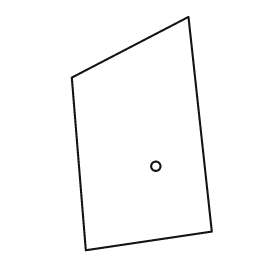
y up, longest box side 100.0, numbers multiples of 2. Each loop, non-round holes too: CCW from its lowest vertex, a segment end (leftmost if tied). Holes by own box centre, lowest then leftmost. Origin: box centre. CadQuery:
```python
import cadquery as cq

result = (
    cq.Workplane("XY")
    .moveTo(-24.0, -50.0)
    .lineTo(30.0, -42.0)
    .lineTo(20.0, 50.0)
    .lineTo(-30.0, 24.0)
    .close()
    .moveTo(6.0, -14.0)
    .circle(2.0)
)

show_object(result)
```